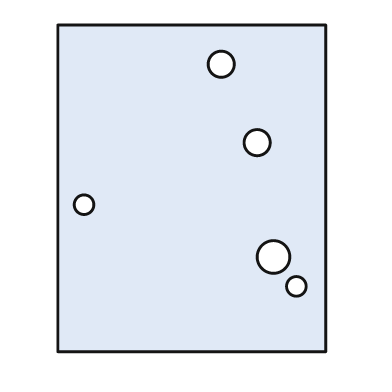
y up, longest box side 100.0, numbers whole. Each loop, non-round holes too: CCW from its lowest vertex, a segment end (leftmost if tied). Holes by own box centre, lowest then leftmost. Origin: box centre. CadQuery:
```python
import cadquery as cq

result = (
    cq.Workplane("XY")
    .moveTo(-41.0, -50.0)
    .lineTo(41.0, -50.0)
    .lineTo(41.0, 50.0)
    .lineTo(-41.0, 50.0)
    .close()
    .moveTo(32.0, -30.0)
    .circle(3.0)
    .moveTo(25.0, -21.0)
    .circle(5.0)
    .moveTo(-33.0, -5.0)
    .circle(3.0)
    .moveTo(20.0, 14.0)
    .circle(4.0)
    .moveTo(9.0, 38.0)
    .circle(4.0)
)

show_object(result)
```